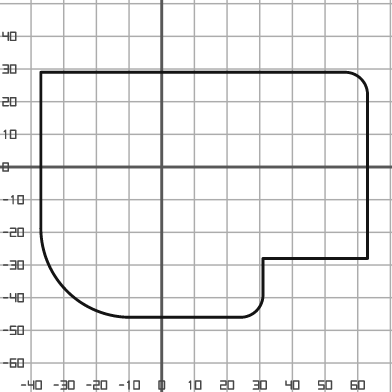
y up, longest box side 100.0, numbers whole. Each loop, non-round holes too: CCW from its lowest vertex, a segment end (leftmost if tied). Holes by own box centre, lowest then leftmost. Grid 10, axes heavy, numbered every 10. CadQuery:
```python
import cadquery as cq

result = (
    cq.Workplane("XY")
    .moveTo(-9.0, -46.0)
    .lineTo(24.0, -46.0)
    .threePointArc((29.0, -44.0), (31.0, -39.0))
    .lineTo(31.0, -28.0)
    .lineTo(63.0, -28.0)
    .lineTo(63.0, 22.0)
    .threePointArc((61.0, 27.0), (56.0, 29.0))
    .lineTo(-37.0, 29.0)
    .lineTo(-37.0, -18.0)
    .threePointArc((-29.0, -38.0), (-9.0, -46.0))
    .close()
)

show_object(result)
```